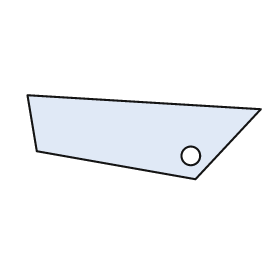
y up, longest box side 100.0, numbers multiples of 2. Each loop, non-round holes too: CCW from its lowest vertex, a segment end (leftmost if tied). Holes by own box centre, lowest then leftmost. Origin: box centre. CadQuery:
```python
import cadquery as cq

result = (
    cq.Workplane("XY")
    .moveTo(22.0, -18.0)
    .lineTo(50.0, 12.0)
    .lineTo(-50.0, 18.0)
    .lineTo(-46.0, -6.0)
    .close()
    .moveTo(20.0, -8.0)
    .circle(4.0)
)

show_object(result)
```